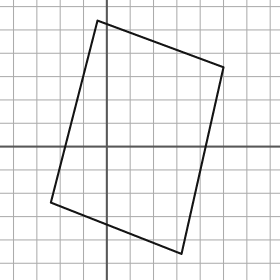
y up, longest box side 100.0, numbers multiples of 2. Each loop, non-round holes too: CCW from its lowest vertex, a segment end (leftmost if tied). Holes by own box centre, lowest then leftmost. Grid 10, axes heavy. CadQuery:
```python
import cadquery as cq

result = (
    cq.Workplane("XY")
    .moveTo(32.0, -46.0)
    .lineTo(50.0, 34.0)
    .lineTo(-4.0, 54.0)
    .lineTo(-24.0, -24.0)
    .close()
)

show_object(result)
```